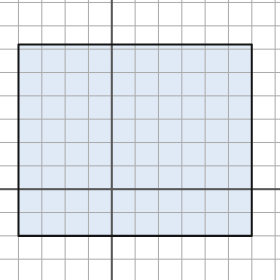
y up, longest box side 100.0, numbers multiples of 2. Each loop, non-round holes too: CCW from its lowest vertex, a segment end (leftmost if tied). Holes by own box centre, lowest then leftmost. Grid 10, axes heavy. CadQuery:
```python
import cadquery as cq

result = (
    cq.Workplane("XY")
    .moveTo(-40.0, -20.0)
    .lineTo(60.0, -20.0)
    .lineTo(60.0, 62.0)
    .lineTo(-40.0, 62.0)
    .close()
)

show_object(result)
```